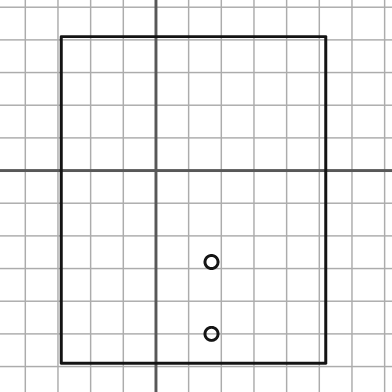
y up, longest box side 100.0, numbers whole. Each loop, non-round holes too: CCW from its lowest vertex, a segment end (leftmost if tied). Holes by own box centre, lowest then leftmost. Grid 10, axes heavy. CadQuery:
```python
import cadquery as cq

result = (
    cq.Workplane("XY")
    .moveTo(-29.0, -59.0)
    .lineTo(52.0, -59.0)
    .lineTo(52.0, 41.0)
    .lineTo(-29.0, 41.0)
    .close()
    .moveTo(17.0, -50.0)
    .circle(2.0)
    .moveTo(17.0, -28.0)
    .circle(2.0)
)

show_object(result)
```